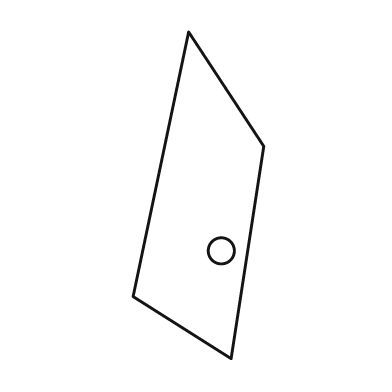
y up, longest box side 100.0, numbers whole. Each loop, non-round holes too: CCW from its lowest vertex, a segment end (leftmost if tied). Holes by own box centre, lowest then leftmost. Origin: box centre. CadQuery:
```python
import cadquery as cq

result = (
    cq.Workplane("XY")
    .moveTo(10.0, -50.0)
    .lineTo(20.0, 15.0)
    .lineTo(-3.0, 50.0)
    .lineTo(-20.0, -31.0)
    .close()
    .moveTo(7.0, -17.0)
    .circle(4.0)
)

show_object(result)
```